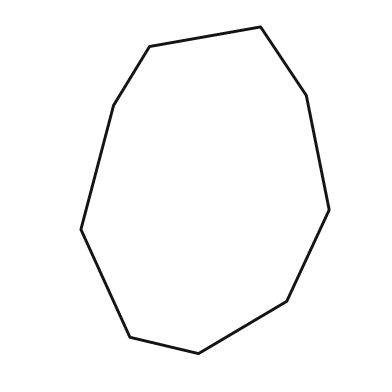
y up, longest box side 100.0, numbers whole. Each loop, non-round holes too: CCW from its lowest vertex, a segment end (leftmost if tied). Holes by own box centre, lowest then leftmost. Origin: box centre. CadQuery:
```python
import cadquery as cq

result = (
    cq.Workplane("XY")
    .moveTo(-2.0, -50.0)
    .lineTo(25.0, -34.0)
    .lineTo(38.0, -6.0)
    .lineTo(31.0, 29.0)
    .lineTo(17.0, 50.0)
    .lineTo(-17.0, 44.0)
    .lineTo(-28.0, 26.0)
    .lineTo(-38.0, -12.0)
    .lineTo(-23.0, -45.0)
    .close()
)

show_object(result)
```